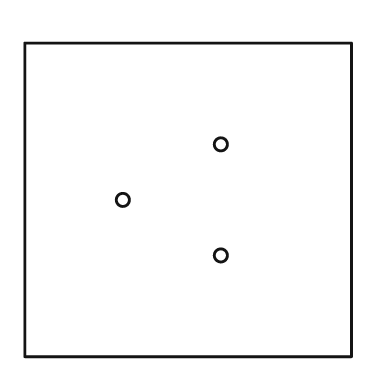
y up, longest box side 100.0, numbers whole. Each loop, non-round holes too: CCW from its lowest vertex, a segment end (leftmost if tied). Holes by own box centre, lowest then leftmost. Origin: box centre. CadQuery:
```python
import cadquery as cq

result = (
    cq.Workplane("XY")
    .moveTo(-50.0, -48.0)
    .lineTo(50.0, -48.0)
    .lineTo(50.0, 48.0)
    .lineTo(-50.0, 48.0)
    .close()
    .moveTo(10.0, -17.0)
    .circle(2.0)
    .moveTo(-20.0, 0.0)
    .circle(2.0)
    .moveTo(10.0, 17.0)
    .circle(2.0)
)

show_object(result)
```